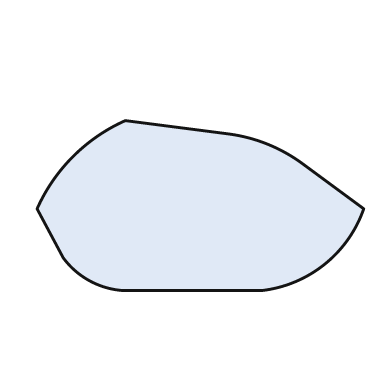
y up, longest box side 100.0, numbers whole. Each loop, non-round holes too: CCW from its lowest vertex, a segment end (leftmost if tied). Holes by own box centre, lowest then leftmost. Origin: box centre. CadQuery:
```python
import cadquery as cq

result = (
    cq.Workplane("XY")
    .moveTo(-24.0, -26.0)
    .lineTo(19.0, -26.0)
    .threePointArc((38.0, -18.0), (50.0, -1.0))
    .lineTo(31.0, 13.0)
    .threePointArc((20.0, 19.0), (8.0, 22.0))
    .lineTo(-23.0, 26.0)
    .threePointArc((-39.0, 15.0), (-50.0, -1.0))
    .lineTo(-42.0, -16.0)
    .threePointArc((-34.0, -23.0), (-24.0, -26.0))
    .close()
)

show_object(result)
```